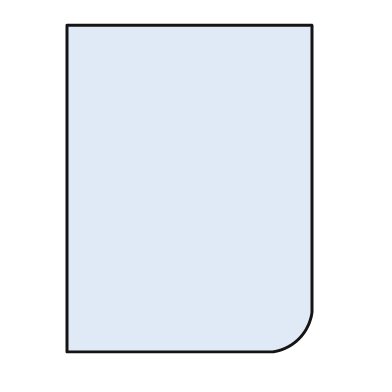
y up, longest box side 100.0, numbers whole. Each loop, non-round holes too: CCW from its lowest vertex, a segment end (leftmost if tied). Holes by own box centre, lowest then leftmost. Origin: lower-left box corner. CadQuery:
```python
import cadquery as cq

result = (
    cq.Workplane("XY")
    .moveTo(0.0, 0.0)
    .lineTo(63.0, 0.0)
    .threePointArc((71.0, 4.0), (75.0, 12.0))
    .lineTo(75.0, 100.0)
    .lineTo(0.0, 100.0)
    .close()
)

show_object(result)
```